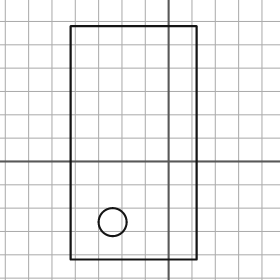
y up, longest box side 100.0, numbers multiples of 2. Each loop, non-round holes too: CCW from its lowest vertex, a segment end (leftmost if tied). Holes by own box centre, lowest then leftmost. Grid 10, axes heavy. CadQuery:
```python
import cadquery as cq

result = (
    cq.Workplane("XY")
    .moveTo(-42.0, -42.0)
    .lineTo(12.0, -42.0)
    .lineTo(12.0, 58.0)
    .lineTo(-42.0, 58.0)
    .close()
    .moveTo(-24.0, -26.0)
    .circle(6.0)
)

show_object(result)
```